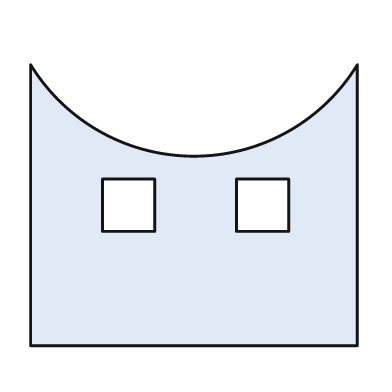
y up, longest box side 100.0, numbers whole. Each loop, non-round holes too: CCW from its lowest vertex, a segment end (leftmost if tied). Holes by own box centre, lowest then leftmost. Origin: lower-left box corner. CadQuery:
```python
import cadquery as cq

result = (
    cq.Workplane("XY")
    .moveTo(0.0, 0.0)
    .lineTo(100.0, 0.0)
    .lineTo(100.0, 86.0)
    .threePointArc((50.0, 58.0), (0.0, 86.0))
    .close()
    .moveTo(22.0, 35.0)
    .lineTo(38.0, 35.0)
    .lineTo(38.0, 51.0)
    .lineTo(22.0, 51.0)
    .close()
    .moveTo(63.0, 35.0)
    .lineTo(79.0, 35.0)
    .lineTo(79.0, 51.0)
    .lineTo(63.0, 51.0)
    .close()
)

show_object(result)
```